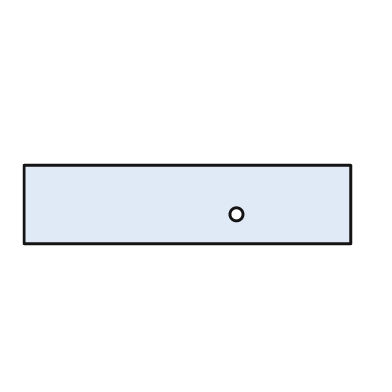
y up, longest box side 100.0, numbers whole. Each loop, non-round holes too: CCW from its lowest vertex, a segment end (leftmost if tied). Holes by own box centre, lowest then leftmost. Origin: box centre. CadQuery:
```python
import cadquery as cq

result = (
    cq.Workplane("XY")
    .moveTo(-50.0, -12.0)
    .lineTo(50.0, -12.0)
    .lineTo(50.0, 12.0)
    .lineTo(-50.0, 12.0)
    .close()
    .moveTo(15.0, -3.0)
    .circle(2.0)
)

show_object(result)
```